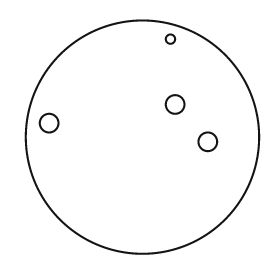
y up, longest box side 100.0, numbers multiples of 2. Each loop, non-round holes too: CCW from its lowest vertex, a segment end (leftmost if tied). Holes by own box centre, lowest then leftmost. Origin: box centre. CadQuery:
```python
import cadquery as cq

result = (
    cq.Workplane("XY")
    .moveTo(0.0, 0.0)
    .circle(50.0)
    .moveTo(28.0, -2.0)
    .circle(4.0)
    .moveTo(-40.0, 6.0)
    .circle(4.0)
    .moveTo(14.0, 14.0)
    .circle(4.0)
    .moveTo(12.0, 42.0)
    .circle(2.0)
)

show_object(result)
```